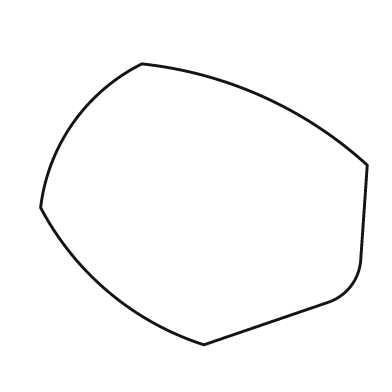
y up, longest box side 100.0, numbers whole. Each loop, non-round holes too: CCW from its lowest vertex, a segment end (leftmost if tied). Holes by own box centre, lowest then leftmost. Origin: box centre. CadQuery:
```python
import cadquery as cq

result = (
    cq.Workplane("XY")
    .moveTo(0.0, -43.0)
    .lineTo(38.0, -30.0)
    .threePointArc((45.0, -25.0), (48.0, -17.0))
    .lineTo(50.0, 12.0)
    .threePointArc((18.0, 33.0), (-19.0, 43.0))
    .threePointArc((-40.0, 25.0), (-50.0, -1.0))
    .threePointArc((-29.0, -27.0), (0.0, -43.0))
    .close()
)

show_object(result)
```